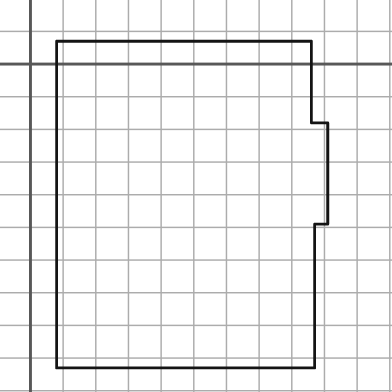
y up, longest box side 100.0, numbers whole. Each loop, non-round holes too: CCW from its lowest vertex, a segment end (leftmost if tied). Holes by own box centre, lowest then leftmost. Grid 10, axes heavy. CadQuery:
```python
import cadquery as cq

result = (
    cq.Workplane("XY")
    .moveTo(8.0, -93.0)
    .lineTo(87.0, -93.0)
    .lineTo(87.0, -49.0)
    .lineTo(91.0, -49.0)
    .lineTo(91.0, -18.0)
    .lineTo(86.0, -18.0)
    .lineTo(86.0, 7.0)
    .lineTo(8.0, 7.0)
    .close()
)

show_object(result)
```